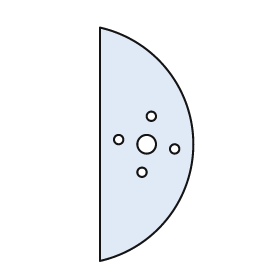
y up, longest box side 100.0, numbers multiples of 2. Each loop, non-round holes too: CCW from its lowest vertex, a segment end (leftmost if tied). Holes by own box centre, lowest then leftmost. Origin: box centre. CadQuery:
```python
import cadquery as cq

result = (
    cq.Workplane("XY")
    .moveTo(-20.0, -50.0)
    .threePointArc((20.0, 0.0), (-20.0, 50.0))
    .close()
    .moveTo(-2.0, -12.0)
    .circle(2.0)
    .moveTo(12.0, -2.0)
    .circle(2.0)
    .moveTo(0.0, 0.0)
    .circle(4.0)
    .moveTo(-12.0, 2.0)
    .circle(2.0)
    .moveTo(2.0, 12.0)
    .circle(2.0)
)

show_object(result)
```